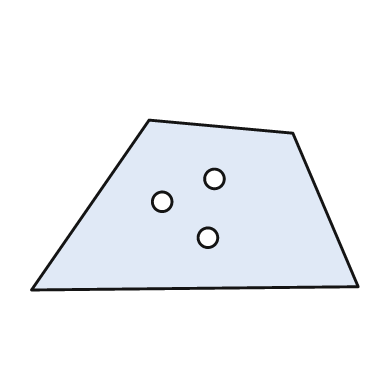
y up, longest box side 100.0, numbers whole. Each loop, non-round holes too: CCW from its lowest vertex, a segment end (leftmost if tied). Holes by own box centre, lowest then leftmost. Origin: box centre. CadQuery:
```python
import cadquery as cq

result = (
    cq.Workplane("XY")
    .moveTo(-50.0, -26.0)
    .lineTo(50.0, -25.0)
    .lineTo(30.0, 22.0)
    .lineTo(-14.0, 26.0)
    .close()
    .moveTo(4.0, -10.0)
    .circle(3.0)
    .moveTo(-10.0, 1.0)
    .circle(3.0)
    .moveTo(6.0, 8.0)
    .circle(3.0)
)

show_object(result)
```